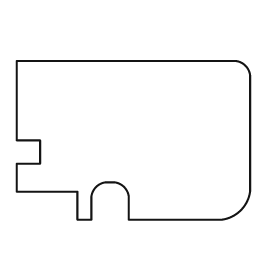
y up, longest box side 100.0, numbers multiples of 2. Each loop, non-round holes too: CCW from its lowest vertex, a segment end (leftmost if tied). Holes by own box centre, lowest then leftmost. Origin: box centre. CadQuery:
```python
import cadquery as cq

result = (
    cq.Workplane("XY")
    .moveTo(-24.0, -34.0)
    .lineTo(-18.0, -34.0)
    .lineTo(-18.0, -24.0)
    .threePointArc((-16.0, -20.0), (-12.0, -18.0))
    .lineTo(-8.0, -18.0)
    .threePointArc((-4.0, -20.0), (-2.0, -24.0))
    .lineTo(-2.0, -34.0)
    .lineTo(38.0, -34.0)
    .threePointArc((46.0, -30.0), (50.0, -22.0))
    .lineTo(50.0, 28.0)
    .threePointArc((48.0, 32.0), (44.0, 34.0))
    .lineTo(-50.0, 34.0)
    .lineTo(-50.0, 0.0)
    .lineTo(-40.0, 0.0)
    .lineTo(-40.0, -10.0)
    .lineTo(-50.0, -10.0)
    .lineTo(-50.0, -22.0)
    .lineTo(-24.0, -22.0)
    .close()
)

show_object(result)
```